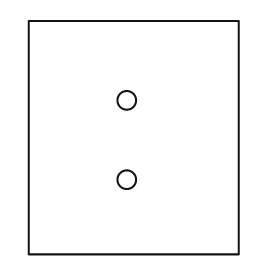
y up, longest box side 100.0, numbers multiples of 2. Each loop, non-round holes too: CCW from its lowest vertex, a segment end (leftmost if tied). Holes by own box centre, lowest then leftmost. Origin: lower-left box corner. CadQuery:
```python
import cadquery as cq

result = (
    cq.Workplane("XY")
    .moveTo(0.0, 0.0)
    .lineTo(90.0, 0.0)
    .lineTo(90.0, 100.0)
    .lineTo(0.0, 100.0)
    .close()
    .moveTo(42.0, 32.0)
    .circle(4.0)
    .moveTo(42.0, 66.0)
    .circle(4.0)
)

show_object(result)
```